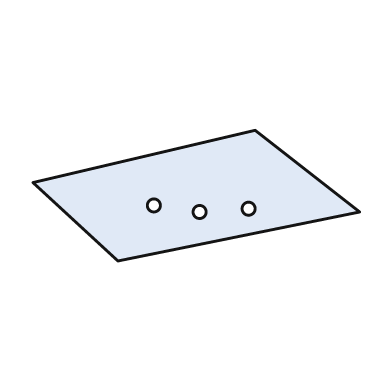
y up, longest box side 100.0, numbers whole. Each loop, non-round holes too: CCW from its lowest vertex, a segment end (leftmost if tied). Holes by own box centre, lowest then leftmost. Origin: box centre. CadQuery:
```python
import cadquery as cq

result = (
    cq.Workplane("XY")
    .moveTo(-24.0, -20.0)
    .lineTo(50.0, -5.0)
    .lineTo(18.0, 20.0)
    .lineTo(-50.0, 4.0)
    .close()
    .moveTo(1.0, -5.0)
    .circle(2.0)
    .moveTo(16.0, -4.0)
    .circle(2.0)
    .moveTo(-13.0, -3.0)
    .circle(2.0)
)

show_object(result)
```